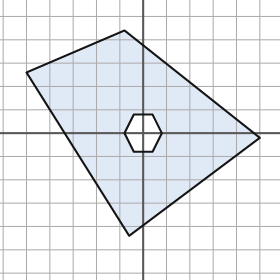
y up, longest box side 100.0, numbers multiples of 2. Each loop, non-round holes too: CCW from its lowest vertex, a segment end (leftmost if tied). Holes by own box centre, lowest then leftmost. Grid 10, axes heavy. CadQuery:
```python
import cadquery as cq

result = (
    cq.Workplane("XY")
    .moveTo(-6.0, -44.0)
    .lineTo(50.0, -2.0)
    .lineTo(-8.0, 44.0)
    .lineTo(-50.0, 26.0)
    .close()
    .moveTo(-4.0, -8.0)
    .lineTo(4.0, -8.0)
    .lineTo(8.0, 0.0)
    .lineTo(4.0, 8.0)
    .lineTo(-4.0, 8.0)
    .lineTo(-8.0, 0.0)
    .close()
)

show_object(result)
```